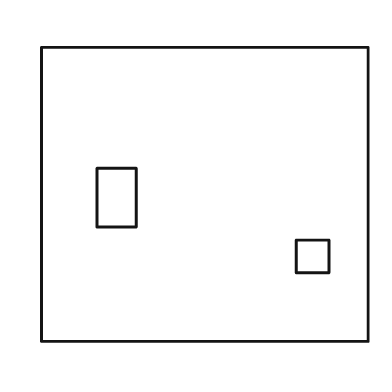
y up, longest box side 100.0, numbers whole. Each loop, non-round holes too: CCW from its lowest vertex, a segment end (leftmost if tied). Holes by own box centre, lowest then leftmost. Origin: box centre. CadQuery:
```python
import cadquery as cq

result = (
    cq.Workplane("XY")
    .moveTo(-50.0, -45.0)
    .lineTo(50.0, -45.0)
    .lineTo(50.0, 45.0)
    .lineTo(-50.0, 45.0)
    .close()
    .moveTo(28.0, -24.0)
    .lineTo(38.0, -24.0)
    .lineTo(38.0, -14.0)
    .lineTo(28.0, -14.0)
    .close()
    .moveTo(-33.0, -10.0)
    .lineTo(-21.0, -10.0)
    .lineTo(-21.0, 8.0)
    .lineTo(-33.0, 8.0)
    .close()
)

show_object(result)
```